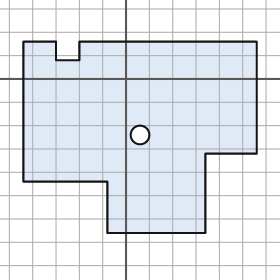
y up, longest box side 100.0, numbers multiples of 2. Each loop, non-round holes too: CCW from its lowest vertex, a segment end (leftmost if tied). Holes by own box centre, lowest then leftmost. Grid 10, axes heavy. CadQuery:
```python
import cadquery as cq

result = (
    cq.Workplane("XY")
    .moveTo(-8.0, -66.0)
    .lineTo(34.0, -66.0)
    .lineTo(34.0, -32.0)
    .lineTo(56.0, -32.0)
    .lineTo(56.0, 16.0)
    .lineTo(-20.0, 16.0)
    .lineTo(-20.0, 8.0)
    .lineTo(-30.0, 8.0)
    .lineTo(-30.0, 16.0)
    .lineTo(-44.0, 16.0)
    .lineTo(-44.0, -44.0)
    .lineTo(-8.0, -44.0)
    .close()
    .moveTo(6.0, -24.0)
    .circle(4.0)
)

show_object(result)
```